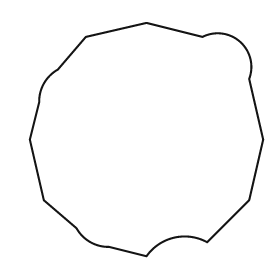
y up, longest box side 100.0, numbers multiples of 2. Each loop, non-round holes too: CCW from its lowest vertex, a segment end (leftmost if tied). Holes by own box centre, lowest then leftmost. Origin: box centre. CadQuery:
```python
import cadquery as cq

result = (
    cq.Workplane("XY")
    .moveTo(0.0, -50.0)
    .threePointArc((12.0, -42.0), (26.0, -44.0))
    .lineTo(44.0, -26.0)
    .lineTo(50.0, 0.0)
    .lineTo(44.0, 26.0)
    .threePointArc((40.0, 42.0), (24.0, 44.0))
    .lineTo(0.0, 50.0)
    .lineTo(-26.0, 44.0)
    .lineTo(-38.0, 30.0)
    .threePointArc((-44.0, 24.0), (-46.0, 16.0))
    .lineTo(-50.0, 0.0)
    .lineTo(-44.0, -26.0)
    .lineTo(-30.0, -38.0)
    .threePointArc((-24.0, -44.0), (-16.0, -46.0))
    .close()
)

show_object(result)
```